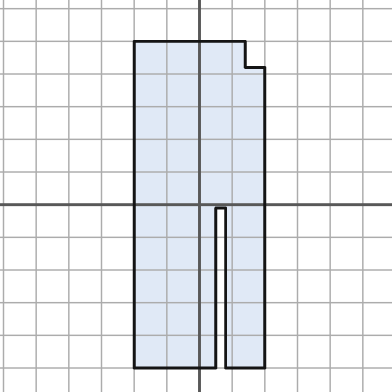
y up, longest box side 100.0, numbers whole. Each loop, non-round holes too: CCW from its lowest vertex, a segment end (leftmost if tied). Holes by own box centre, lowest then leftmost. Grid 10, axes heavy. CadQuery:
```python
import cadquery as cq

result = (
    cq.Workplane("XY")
    .moveTo(-20.0, -50.0)
    .lineTo(5.0, -50.0)
    .lineTo(5.0, -1.0)
    .lineTo(8.0, -1.0)
    .lineTo(8.0, -50.0)
    .lineTo(20.0, -50.0)
    .lineTo(20.0, 42.0)
    .lineTo(14.0, 42.0)
    .lineTo(14.0, 50.0)
    .lineTo(-20.0, 50.0)
    .close()
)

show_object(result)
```